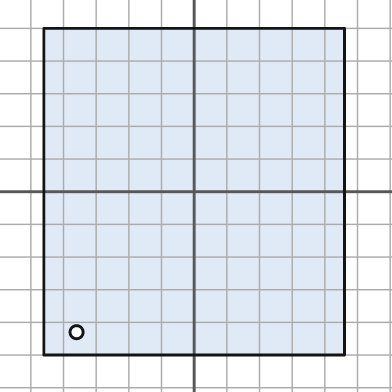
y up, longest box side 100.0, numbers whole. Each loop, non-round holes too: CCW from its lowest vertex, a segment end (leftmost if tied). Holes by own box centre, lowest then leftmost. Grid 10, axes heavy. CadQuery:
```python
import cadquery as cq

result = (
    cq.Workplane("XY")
    .moveTo(-46.0, -50.0)
    .lineTo(46.0, -50.0)
    .lineTo(46.0, 50.0)
    .lineTo(-46.0, 50.0)
    .close()
    .moveTo(-36.0, -43.0)
    .circle(2.0)
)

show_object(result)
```